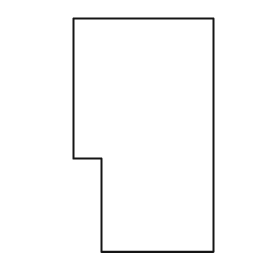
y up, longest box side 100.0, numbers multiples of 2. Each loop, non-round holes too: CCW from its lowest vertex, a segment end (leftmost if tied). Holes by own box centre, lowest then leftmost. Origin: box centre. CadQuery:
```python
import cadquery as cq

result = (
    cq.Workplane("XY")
    .moveTo(-18.0, -50.0)
    .lineTo(30.0, -50.0)
    .lineTo(30.0, 50.0)
    .lineTo(-30.0, 50.0)
    .lineTo(-30.0, -10.0)
    .lineTo(-18.0, -10.0)
    .close()
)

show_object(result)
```